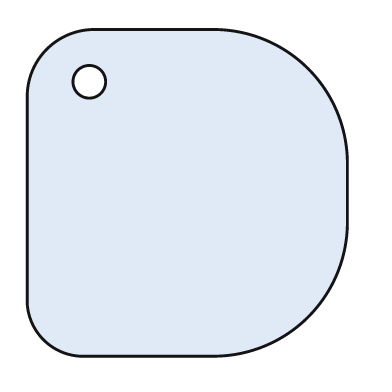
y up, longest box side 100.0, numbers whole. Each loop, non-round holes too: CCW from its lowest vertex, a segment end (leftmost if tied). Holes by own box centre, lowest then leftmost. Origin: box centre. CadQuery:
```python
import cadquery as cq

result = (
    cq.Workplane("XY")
    .moveTo(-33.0, -50.0)
    .lineTo(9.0, -50.0)
    .threePointArc((37.0, -38.0), (49.0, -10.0))
    .lineTo(49.0, 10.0)
    .threePointArc((37.0, 38.0), (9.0, 50.0))
    .lineTo(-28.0, 50.0)
    .threePointArc((-43.0, 44.0), (-49.0, 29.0))
    .lineTo(-49.0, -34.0)
    .threePointArc((-44.0, -45.0), (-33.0, -50.0))
    .close()
    .moveTo(-30.0, 34.0)
    .circle(5.0)
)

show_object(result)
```